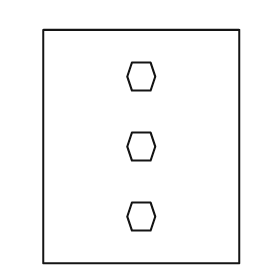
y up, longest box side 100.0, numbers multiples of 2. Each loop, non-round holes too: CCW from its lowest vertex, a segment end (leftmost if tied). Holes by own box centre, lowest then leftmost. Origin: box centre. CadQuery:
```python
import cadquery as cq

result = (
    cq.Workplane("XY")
    .moveTo(-42.0, -50.0)
    .lineTo(42.0, -50.0)
    .lineTo(42.0, 50.0)
    .lineTo(-42.0, 50.0)
    .close()
    .moveTo(-4.0, -36.0)
    .lineTo(4.0, -36.0)
    .lineTo(6.0, -30.0)
    .lineTo(4.0, -24.0)
    .lineTo(-4.0, -24.0)
    .lineTo(-6.0, -30.0)
    .close()
    .moveTo(-4.0, -6.0)
    .lineTo(4.0, -6.0)
    .lineTo(6.0, 0.0)
    .lineTo(4.0, 6.0)
    .lineTo(-4.0, 6.0)
    .lineTo(-6.0, 0.0)
    .close()
    .moveTo(-4.0, 24.0)
    .lineTo(4.0, 24.0)
    .lineTo(6.0, 30.0)
    .lineTo(4.0, 36.0)
    .lineTo(-4.0, 36.0)
    .lineTo(-6.0, 30.0)
    .close()
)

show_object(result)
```